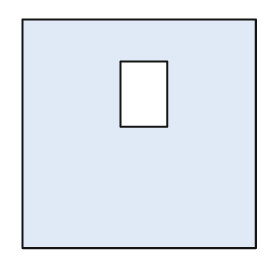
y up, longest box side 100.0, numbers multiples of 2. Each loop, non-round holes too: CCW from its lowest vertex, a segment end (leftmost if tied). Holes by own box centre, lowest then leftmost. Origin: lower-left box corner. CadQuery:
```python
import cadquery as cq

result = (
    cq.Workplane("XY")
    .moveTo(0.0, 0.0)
    .lineTo(100.0, 0.0)
    .lineTo(100.0, 98.0)
    .lineTo(0.0, 98.0)
    .close()
    .moveTo(42.0, 52.0)
    .lineTo(62.0, 52.0)
    .lineTo(62.0, 80.0)
    .lineTo(42.0, 80.0)
    .close()
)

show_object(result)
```